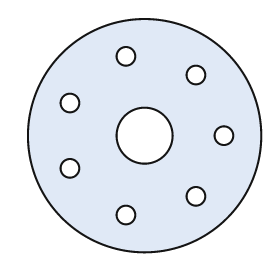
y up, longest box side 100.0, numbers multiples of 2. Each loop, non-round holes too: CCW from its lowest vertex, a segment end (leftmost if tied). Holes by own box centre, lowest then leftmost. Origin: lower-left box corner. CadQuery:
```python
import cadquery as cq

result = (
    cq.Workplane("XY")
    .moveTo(50.0, 50.0)
    .circle(50.0)
    .moveTo(42.0, 16.0)
    .circle(4.0)
    .moveTo(72.0, 24.0)
    .circle(4.0)
    .moveTo(18.0, 36.0)
    .circle(4.0)
    .moveTo(50.0, 50.0)
    .circle(12.0)
    .moveTo(84.0, 50.0)
    .circle(4.0)
    .moveTo(18.0, 64.0)
    .circle(4.0)
    .moveTo(72.0, 76.0)
    .circle(4.0)
    .moveTo(42.0, 84.0)
    .circle(4.0)
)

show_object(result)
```